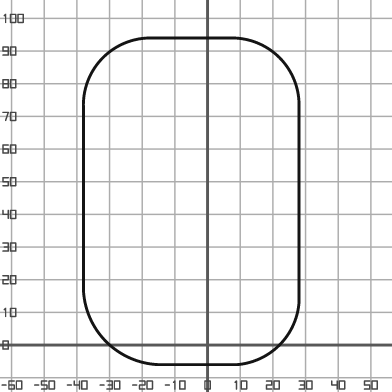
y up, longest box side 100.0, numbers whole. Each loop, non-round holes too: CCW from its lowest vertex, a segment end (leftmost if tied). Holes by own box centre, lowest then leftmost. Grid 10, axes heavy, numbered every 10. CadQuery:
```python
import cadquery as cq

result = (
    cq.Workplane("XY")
    .moveTo(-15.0, -6.0)
    .lineTo(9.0, -6.0)
    .threePointArc((22.0, 0.0), (28.0, 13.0))
    .lineTo(28.0, 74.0)
    .threePointArc((22.0, 88.0), (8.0, 94.0))
    .lineTo(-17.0, 94.0)
    .threePointArc((-32.0, 88.0), (-38.0, 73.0))
    .lineTo(-38.0, 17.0)
    .threePointArc((-31.0, 1.0), (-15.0, -6.0))
    .close()
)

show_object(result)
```